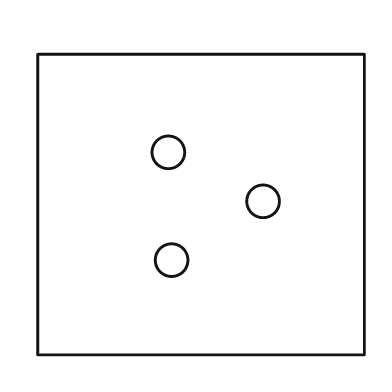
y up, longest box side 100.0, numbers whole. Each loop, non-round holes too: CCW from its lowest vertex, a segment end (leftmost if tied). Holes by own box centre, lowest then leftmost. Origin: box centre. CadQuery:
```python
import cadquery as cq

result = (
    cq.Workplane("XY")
    .moveTo(-50.0, -46.0)
    .lineTo(50.0, -46.0)
    .lineTo(50.0, 46.0)
    .lineTo(-50.0, 46.0)
    .close()
    .moveTo(-9.0, -17.0)
    .circle(5.0)
    .moveTo(19.0, 1.0)
    .circle(5.0)
    .moveTo(-10.0, 16.0)
    .circle(5.0)
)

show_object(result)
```